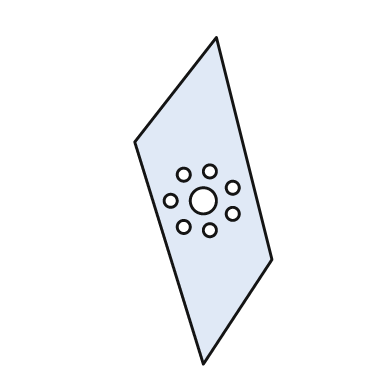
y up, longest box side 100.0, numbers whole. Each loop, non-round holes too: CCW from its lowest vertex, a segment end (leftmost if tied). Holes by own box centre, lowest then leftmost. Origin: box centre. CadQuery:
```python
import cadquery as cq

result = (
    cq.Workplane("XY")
    .moveTo(0.0, -50.0)
    .lineTo(21.0, -18.0)
    .lineTo(4.0, 50.0)
    .lineTo(-21.0, 18.0)
    .close()
    .moveTo(2.0, -9.0)
    .circle(2.0)
    .moveTo(-6.0, -8.0)
    .circle(2.0)
    .moveTo(9.0, -4.0)
    .circle(2.0)
    .moveTo(-10.0, 0.0)
    .circle(2.0)
    .moveTo(0.0, 0.0)
    .circle(4.0)
    .moveTo(9.0, 4.0)
    .circle(2.0)
    .moveTo(-6.0, 8.0)
    .circle(2.0)
    .moveTo(2.0, 9.0)
    .circle(2.0)
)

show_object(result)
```